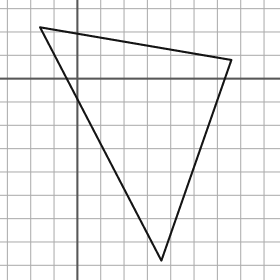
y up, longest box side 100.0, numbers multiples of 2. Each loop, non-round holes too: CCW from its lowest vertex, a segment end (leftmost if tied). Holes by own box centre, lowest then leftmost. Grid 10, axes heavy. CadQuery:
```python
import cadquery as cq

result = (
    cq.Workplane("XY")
    .moveTo(36.0, -78.0)
    .lineTo(66.0, 8.0)
    .lineTo(-16.0, 22.0)
    .close()
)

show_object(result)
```